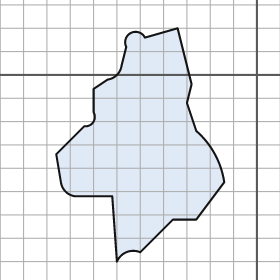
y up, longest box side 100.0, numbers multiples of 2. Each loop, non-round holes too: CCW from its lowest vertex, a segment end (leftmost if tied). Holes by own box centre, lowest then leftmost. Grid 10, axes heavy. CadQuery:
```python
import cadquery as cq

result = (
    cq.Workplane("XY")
    .moveTo(-60.0, -80.0)
    .threePointArc((-56.0, -76.0), (-50.0, -76.0))
    .lineTo(-36.0, -62.0)
    .lineTo(-26.0, -62.0)
    .lineTo(-14.0, -46.0)
    .threePointArc((-18.0, -34.0), (-26.0, -24.0))
    .lineTo(-30.0, -12.0)
    .lineTo(-28.0, -4.0)
    .lineTo(-34.0, 20.0)
    .lineTo(-48.0, 16.0)
    .threePointArc((-54.0, 18.0), (-56.0, 12.0))
    .lineTo(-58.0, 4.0)
    .threePointArc((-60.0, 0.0), (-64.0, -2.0))
    .lineTo(-70.0, -6.0)
    .lineTo(-70.0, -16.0)
    .threePointArc((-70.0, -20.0), (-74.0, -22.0))
    .lineTo(-86.0, -34.0)
    .lineTo(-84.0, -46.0)
    .threePointArc((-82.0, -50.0), (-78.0, -52.0))
    .lineTo(-62.0, -52.0)
    .close()
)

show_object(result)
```